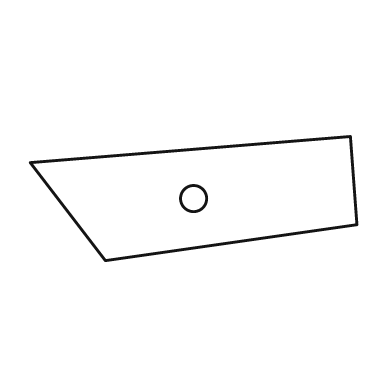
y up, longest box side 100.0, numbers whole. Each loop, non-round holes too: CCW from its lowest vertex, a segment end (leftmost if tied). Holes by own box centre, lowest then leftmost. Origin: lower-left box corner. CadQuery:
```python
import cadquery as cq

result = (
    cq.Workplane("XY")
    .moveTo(23.0, 0.0)
    .lineTo(100.0, 11.0)
    .lineTo(98.0, 38.0)
    .lineTo(0.0, 30.0)
    .close()
    .moveTo(50.0, 19.0)
    .circle(4.0)
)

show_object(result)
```